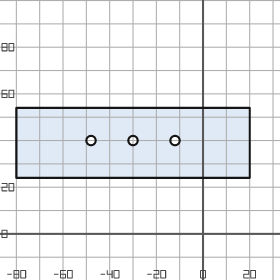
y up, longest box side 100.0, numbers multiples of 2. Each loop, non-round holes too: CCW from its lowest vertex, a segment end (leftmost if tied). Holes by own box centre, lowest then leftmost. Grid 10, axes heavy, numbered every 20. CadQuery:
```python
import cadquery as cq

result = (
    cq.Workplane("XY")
    .moveTo(-80.0, 24.0)
    .lineTo(20.0, 24.0)
    .lineTo(20.0, 54.0)
    .lineTo(-80.0, 54.0)
    .close()
    .moveTo(-48.0, 40.0)
    .circle(2.0)
    .moveTo(-30.0, 40.0)
    .circle(2.0)
    .moveTo(-12.0, 40.0)
    .circle(2.0)
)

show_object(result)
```